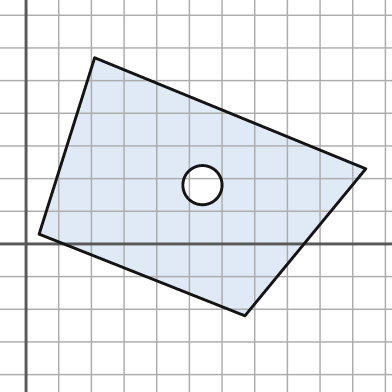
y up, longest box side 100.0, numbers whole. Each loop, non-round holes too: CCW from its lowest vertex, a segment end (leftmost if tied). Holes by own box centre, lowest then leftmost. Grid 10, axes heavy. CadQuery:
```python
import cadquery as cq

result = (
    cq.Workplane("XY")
    .moveTo(67.0, -22.0)
    .lineTo(104.0, 23.0)
    .lineTo(21.0, 57.0)
    .lineTo(4.0, 3.0)
    .close()
    .moveTo(54.0, 18.0)
    .circle(6.0)
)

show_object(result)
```